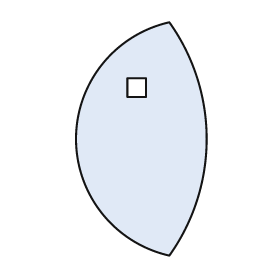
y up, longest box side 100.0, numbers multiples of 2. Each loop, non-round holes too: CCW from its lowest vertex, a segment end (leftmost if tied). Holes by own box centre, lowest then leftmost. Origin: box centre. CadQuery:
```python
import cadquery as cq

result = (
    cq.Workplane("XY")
    .moveTo(12.0, -50.0)
    .threePointArc((28.0, 0.0), (12.0, 50.0))
    .threePointArc((-28.0, 0.0), (12.0, -50.0))
    .close()
    .moveTo(-6.0, 18.0)
    .lineTo(2.0, 18.0)
    .lineTo(2.0, 26.0)
    .lineTo(-6.0, 26.0)
    .close()
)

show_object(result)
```